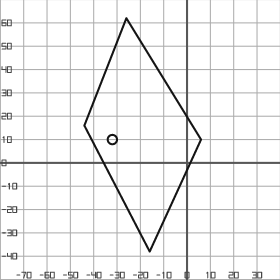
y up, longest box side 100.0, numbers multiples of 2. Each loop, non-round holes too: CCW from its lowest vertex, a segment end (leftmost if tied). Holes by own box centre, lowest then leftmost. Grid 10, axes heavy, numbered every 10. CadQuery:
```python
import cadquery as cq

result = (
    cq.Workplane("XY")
    .moveTo(-16.0, -38.0)
    .lineTo(6.0, 10.0)
    .lineTo(-26.0, 62.0)
    .lineTo(-44.0, 16.0)
    .close()
    .moveTo(-32.0, 10.0)
    .circle(2.0)
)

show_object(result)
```